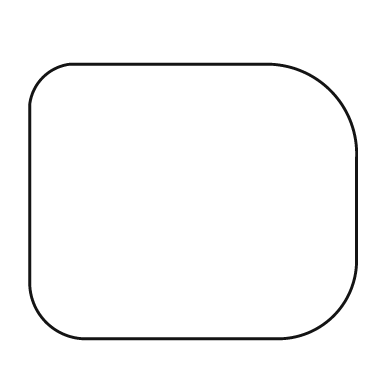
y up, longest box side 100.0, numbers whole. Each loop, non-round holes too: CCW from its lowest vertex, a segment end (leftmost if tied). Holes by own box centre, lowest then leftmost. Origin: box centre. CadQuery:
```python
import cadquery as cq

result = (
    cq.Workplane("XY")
    .moveTo(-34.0, -42.0)
    .lineTo(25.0, -42.0)
    .threePointArc((43.0, -35.0), (50.0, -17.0))
    .lineTo(50.0, 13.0)
    .threePointArc((42.0, 34.0), (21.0, 42.0))
    .lineTo(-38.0, 42.0)
    .threePointArc((-46.0, 38.0), (-50.0, 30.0))
    .lineTo(-50.0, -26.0)
    .threePointArc((-45.0, -37.0), (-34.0, -42.0))
    .close()
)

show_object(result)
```